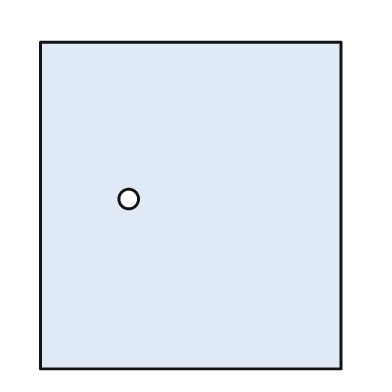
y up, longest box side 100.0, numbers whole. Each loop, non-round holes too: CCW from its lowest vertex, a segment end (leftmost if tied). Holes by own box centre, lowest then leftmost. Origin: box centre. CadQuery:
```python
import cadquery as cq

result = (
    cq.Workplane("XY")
    .moveTo(-46.0, -50.0)
    .lineTo(46.0, -50.0)
    .lineTo(46.0, 50.0)
    .lineTo(-46.0, 50.0)
    .close()
    .moveTo(-19.0, 2.0)
    .circle(3.0)
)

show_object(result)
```